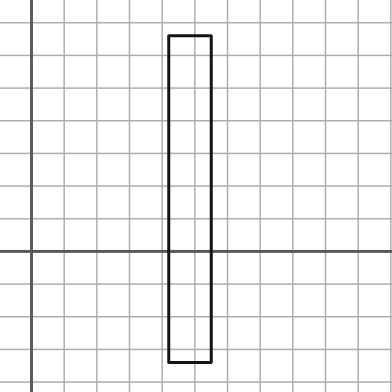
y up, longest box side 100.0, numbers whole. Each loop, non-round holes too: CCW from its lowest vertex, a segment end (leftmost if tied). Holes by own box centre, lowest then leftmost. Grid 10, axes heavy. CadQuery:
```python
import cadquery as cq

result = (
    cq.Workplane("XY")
    .moveTo(42.0, -34.0)
    .lineTo(55.0, -34.0)
    .lineTo(55.0, 66.0)
    .lineTo(42.0, 66.0)
    .close()
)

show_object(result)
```